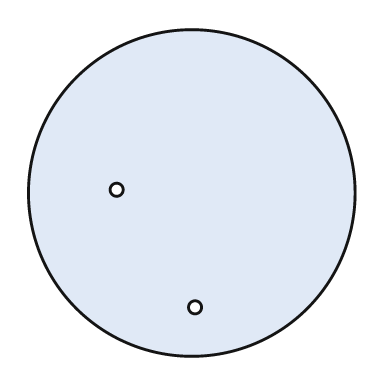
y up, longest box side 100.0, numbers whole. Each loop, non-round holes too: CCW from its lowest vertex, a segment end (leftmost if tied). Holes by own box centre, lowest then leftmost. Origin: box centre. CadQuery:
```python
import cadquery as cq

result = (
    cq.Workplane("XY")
    .moveTo(0.0, 0.0)
    .circle(50.0)
    .moveTo(1.0, -35.0)
    .circle(2.0)
    .moveTo(-23.0, 1.0)
    .circle(2.0)
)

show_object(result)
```